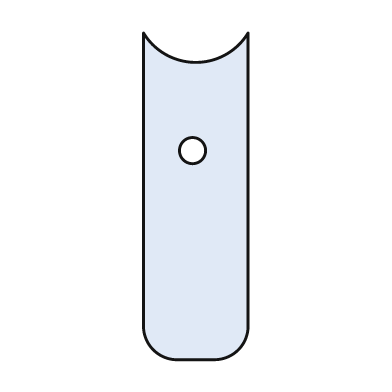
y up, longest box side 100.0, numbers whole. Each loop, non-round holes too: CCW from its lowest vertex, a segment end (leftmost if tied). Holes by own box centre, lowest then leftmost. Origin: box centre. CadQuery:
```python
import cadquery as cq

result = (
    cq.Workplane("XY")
    .moveTo(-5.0, -50.0)
    .lineTo(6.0, -50.0)
    .threePointArc((13.0, -47.0), (16.0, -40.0))
    .lineTo(16.0, 50.0)
    .threePointArc((0.0, 41.0), (-16.0, 50.0))
    .lineTo(-16.0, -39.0)
    .threePointArc((-13.0, -47.0), (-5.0, -50.0))
    .close()
    .moveTo(-1.0, 14.0)
    .circle(4.0)
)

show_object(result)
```